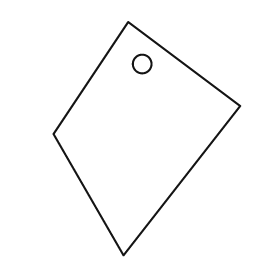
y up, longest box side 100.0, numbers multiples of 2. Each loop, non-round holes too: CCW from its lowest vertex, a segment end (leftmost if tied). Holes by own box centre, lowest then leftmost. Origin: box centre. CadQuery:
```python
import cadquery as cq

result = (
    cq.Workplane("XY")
    .moveTo(-10.0, -50.0)
    .lineTo(40.0, 14.0)
    .lineTo(-8.0, 50.0)
    .lineTo(-40.0, 2.0)
    .close()
    .moveTo(-2.0, 32.0)
    .circle(4.0)
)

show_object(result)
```